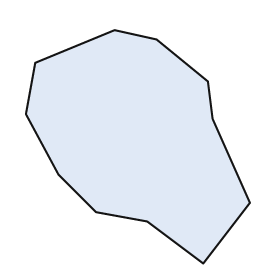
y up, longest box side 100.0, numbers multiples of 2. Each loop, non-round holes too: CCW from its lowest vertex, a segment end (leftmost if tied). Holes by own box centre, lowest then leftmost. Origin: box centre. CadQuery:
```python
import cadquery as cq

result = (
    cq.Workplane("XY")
    .moveTo(28.0, -50.0)
    .lineTo(48.0, -24.0)
    .lineTo(32.0, 12.0)
    .lineTo(30.0, 28.0)
    .lineTo(8.0, 46.0)
    .lineTo(-10.0, 50.0)
    .lineTo(-44.0, 36.0)
    .lineTo(-48.0, 14.0)
    .lineTo(-34.0, -12.0)
    .lineTo(-18.0, -28.0)
    .lineTo(4.0, -32.0)
    .close()
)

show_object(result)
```